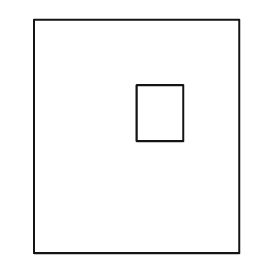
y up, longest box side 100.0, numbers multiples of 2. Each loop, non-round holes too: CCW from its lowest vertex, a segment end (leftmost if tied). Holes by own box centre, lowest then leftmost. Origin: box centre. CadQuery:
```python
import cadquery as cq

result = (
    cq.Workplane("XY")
    .moveTo(-44.0, -50.0)
    .lineTo(44.0, -50.0)
    .lineTo(44.0, 50.0)
    .lineTo(-44.0, 50.0)
    .close()
    .moveTo(0.0, -2.0)
    .lineTo(20.0, -2.0)
    .lineTo(20.0, 22.0)
    .lineTo(0.0, 22.0)
    .close()
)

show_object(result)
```